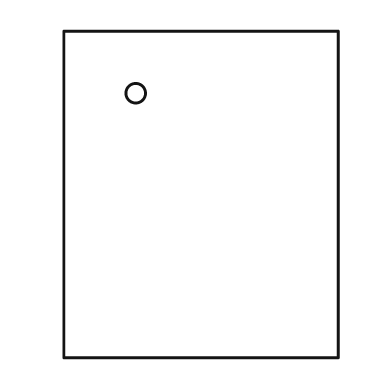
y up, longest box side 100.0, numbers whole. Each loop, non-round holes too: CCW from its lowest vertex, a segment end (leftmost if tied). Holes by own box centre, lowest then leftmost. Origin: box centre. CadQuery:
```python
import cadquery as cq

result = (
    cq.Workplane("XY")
    .moveTo(-42.0, -50.0)
    .lineTo(42.0, -50.0)
    .lineTo(42.0, 50.0)
    .lineTo(-42.0, 50.0)
    .close()
    .moveTo(-20.0, 31.0)
    .circle(3.0)
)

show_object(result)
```